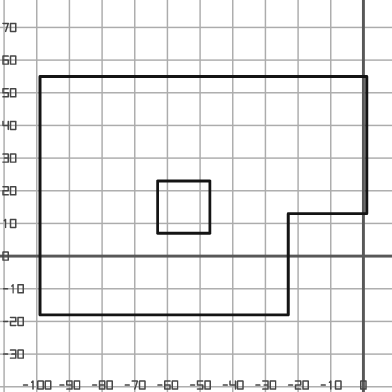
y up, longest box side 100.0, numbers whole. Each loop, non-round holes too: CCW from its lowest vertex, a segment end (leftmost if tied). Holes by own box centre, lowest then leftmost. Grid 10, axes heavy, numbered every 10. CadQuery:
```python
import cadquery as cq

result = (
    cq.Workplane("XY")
    .moveTo(-99.0, -18.0)
    .lineTo(-23.0, -18.0)
    .lineTo(-23.0, 13.0)
    .lineTo(1.0, 13.0)
    .lineTo(1.0, 55.0)
    .lineTo(-99.0, 55.0)
    .close()
    .moveTo(-63.0, 7.0)
    .lineTo(-47.0, 7.0)
    .lineTo(-47.0, 23.0)
    .lineTo(-63.0, 23.0)
    .close()
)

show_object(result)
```